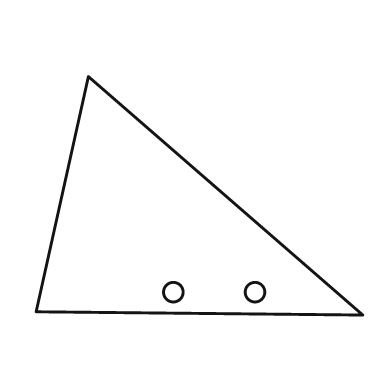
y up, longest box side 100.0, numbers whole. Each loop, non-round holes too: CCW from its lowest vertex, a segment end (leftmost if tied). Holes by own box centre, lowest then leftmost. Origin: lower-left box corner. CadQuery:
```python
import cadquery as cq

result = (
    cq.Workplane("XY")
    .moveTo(100.0, 0.0)
    .lineTo(16.0, 73.0)
    .lineTo(0.0, 1.0)
    .close()
    .moveTo(42.0, 7.0)
    .circle(3.0)
    .moveTo(67.0, 7.0)
    .circle(3.0)
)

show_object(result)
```